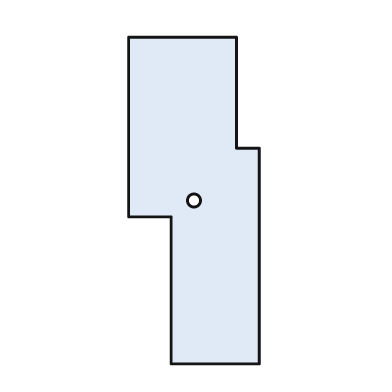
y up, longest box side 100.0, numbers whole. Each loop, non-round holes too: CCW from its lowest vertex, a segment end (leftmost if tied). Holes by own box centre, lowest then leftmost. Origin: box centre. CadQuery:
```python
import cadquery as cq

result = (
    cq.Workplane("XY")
    .moveTo(-7.0, -50.0)
    .lineTo(20.0, -50.0)
    .lineTo(20.0, 16.0)
    .lineTo(13.0, 16.0)
    .lineTo(13.0, 50.0)
    .lineTo(-20.0, 50.0)
    .lineTo(-20.0, -5.0)
    .lineTo(-7.0, -5.0)
    .close()
    .moveTo(0.0, 0.0)
    .circle(2.0)
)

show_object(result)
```